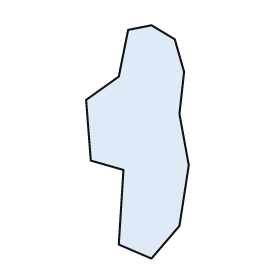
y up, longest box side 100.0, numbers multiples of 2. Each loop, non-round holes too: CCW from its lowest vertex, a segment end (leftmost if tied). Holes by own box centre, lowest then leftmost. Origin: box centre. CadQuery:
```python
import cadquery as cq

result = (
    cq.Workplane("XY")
    .moveTo(6.0, -50.0)
    .lineTo(18.0, -36.0)
    .lineTo(22.0, -10.0)
    .lineTo(18.0, 12.0)
    .lineTo(20.0, 30.0)
    .lineTo(16.0, 44.0)
    .lineTo(6.0, 50.0)
    .lineTo(-4.0, 48.0)
    .lineTo(-8.0, 28.0)
    .lineTo(-22.0, 18.0)
    .lineTo(-20.0, -8.0)
    .lineTo(-6.0, -12.0)
    .lineTo(-8.0, -44.0)
    .close()
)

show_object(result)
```